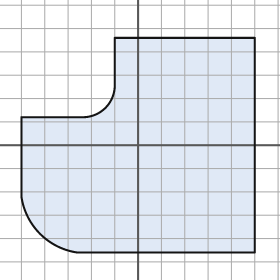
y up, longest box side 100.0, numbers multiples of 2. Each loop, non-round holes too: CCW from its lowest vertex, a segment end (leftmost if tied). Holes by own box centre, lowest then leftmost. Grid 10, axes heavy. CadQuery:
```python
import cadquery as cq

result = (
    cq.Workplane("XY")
    .moveTo(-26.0, -46.0)
    .lineTo(50.0, -46.0)
    .lineTo(50.0, 46.0)
    .lineTo(-10.0, 46.0)
    .lineTo(-10.0, 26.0)
    .threePointArc((-14.0, 16.0), (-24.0, 12.0))
    .lineTo(-50.0, 12.0)
    .lineTo(-50.0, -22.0)
    .threePointArc((-42.0, -38.0), (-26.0, -46.0))
    .close()
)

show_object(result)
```